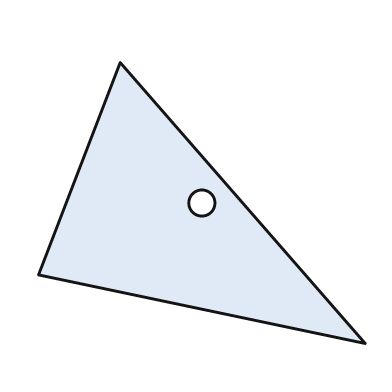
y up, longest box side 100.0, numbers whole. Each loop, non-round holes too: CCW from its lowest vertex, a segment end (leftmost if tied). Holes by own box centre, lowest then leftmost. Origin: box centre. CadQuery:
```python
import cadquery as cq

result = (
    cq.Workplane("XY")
    .moveTo(50.0, -43.0)
    .lineTo(-25.0, 43.0)
    .lineTo(-50.0, -22.0)
    .close()
    .moveTo(0.0, 0.0)
    .circle(4.0)
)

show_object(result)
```